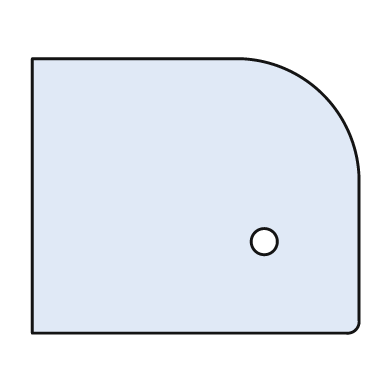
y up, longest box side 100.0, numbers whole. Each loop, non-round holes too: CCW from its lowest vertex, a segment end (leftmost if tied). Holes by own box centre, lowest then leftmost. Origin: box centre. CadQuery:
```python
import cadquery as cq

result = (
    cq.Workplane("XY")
    .moveTo(-50.0, -42.0)
    .lineTo(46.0, -42.0)
    .threePointArc((49.0, -41.0), (50.0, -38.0))
    .lineTo(50.0, 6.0)
    .threePointArc((39.0, 31.0), (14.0, 42.0))
    .lineTo(-50.0, 42.0)
    .close()
    .moveTo(21.0, -14.0)
    .circle(4.0)
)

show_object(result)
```